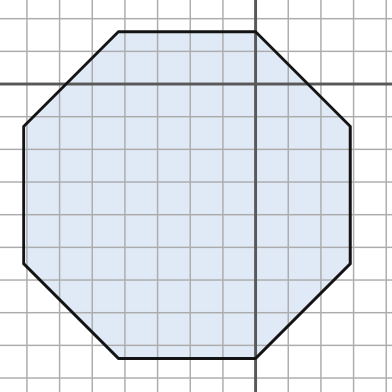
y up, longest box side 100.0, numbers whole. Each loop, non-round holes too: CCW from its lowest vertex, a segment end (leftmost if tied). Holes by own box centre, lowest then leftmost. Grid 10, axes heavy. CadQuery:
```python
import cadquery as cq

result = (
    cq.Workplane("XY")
    .moveTo(-42.0, -84.0)
    .lineTo(0.0, -84.0)
    .lineTo(29.0, -55.0)
    .lineTo(29.0, -13.0)
    .lineTo(0.0, 16.0)
    .lineTo(-42.0, 16.0)
    .lineTo(-71.0, -13.0)
    .lineTo(-71.0, -55.0)
    .close()
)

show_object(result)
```